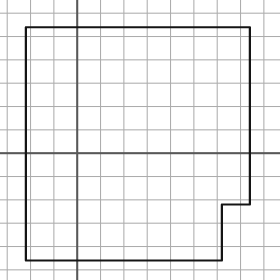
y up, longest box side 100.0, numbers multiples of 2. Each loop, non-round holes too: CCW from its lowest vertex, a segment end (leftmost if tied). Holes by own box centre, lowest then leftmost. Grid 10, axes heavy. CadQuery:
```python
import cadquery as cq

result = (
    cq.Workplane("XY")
    .moveTo(-22.0, -46.0)
    .lineTo(62.0, -46.0)
    .lineTo(62.0, -22.0)
    .lineTo(74.0, -22.0)
    .lineTo(74.0, 54.0)
    .lineTo(-22.0, 54.0)
    .close()
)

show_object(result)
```